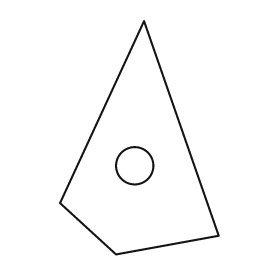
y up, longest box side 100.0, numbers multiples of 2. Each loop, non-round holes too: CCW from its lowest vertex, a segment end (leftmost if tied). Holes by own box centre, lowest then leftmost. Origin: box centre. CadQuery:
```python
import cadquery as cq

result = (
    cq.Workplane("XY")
    .moveTo(-10.0, -50.0)
    .lineTo(34.0, -42.0)
    .lineTo(2.0, 50.0)
    .lineTo(-34.0, -28.0)
    .close()
    .moveTo(-2.0, -12.0)
    .circle(8.0)
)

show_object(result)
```